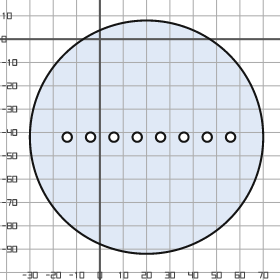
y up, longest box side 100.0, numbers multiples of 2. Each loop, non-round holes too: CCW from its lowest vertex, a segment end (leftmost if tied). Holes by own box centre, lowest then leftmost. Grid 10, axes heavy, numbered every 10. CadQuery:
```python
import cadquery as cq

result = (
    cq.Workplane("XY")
    .moveTo(20.0, -42.0)
    .circle(50.0)
    .moveTo(-14.0, -42.0)
    .circle(2.0)
    .moveTo(-4.0, -42.0)
    .circle(2.0)
    .moveTo(6.0, -42.0)
    .circle(2.0)
    .moveTo(16.0, -42.0)
    .circle(2.0)
    .moveTo(26.0, -42.0)
    .circle(2.0)
    .moveTo(36.0, -42.0)
    .circle(2.0)
    .moveTo(46.0, -42.0)
    .circle(2.0)
    .moveTo(56.0, -42.0)
    .circle(2.0)
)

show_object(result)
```